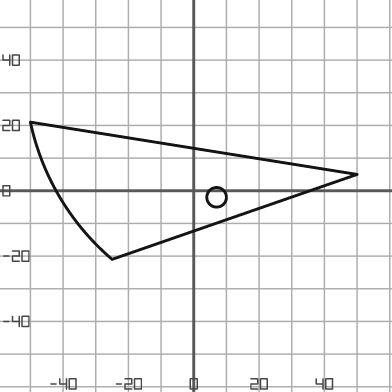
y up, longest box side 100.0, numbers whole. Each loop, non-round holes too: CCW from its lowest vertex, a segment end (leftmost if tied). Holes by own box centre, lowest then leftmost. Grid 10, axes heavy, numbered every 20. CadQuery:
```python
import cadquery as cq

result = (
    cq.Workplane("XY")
    .moveTo(-25.0, -21.0)
    .lineTo(50.0, 5.0)
    .lineTo(-50.0, 21.0)
    .threePointArc((-41.0, -2.0), (-25.0, -21.0))
    .close()
    .moveTo(7.0, -2.0)
    .circle(3.0)
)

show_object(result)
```